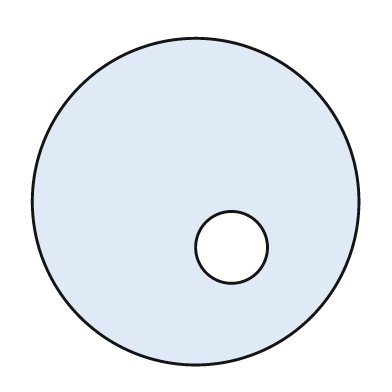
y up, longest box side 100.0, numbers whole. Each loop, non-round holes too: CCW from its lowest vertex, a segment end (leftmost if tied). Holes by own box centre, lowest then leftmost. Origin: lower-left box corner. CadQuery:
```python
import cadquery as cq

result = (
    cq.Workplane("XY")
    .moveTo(50.0, 50.0)
    .circle(50.0)
    .moveTo(61.0, 36.0)
    .circle(11.0)
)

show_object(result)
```